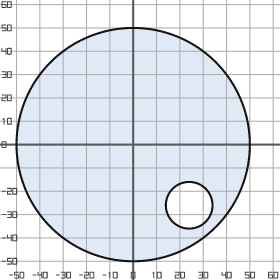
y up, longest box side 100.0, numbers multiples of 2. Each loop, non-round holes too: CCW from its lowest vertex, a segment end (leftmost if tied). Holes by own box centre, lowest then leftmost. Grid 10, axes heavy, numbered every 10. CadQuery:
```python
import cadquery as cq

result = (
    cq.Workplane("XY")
    .moveTo(0.0, 0.0)
    .circle(50.0)
    .moveTo(24.0, -26.0)
    .circle(10.0)
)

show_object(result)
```